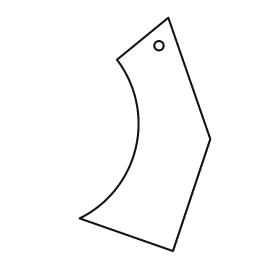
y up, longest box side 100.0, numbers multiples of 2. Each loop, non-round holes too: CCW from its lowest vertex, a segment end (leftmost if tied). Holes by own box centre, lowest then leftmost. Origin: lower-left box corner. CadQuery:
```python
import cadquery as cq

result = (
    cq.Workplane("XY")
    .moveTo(40.0, 0.0)
    .lineTo(56.0, 48.0)
    .lineTo(38.0, 100.0)
    .lineTo(16.0, 82.0)
    .threePointArc((24.0, 44.0), (0.0, 14.0))
    .close()
    .moveTo(34.0, 88.0)
    .circle(2.0)
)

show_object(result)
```